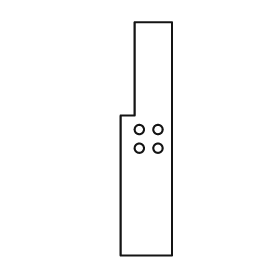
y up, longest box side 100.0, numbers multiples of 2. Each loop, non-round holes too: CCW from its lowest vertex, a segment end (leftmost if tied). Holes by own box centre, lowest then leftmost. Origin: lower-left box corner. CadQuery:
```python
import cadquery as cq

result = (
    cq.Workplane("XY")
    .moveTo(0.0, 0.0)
    .lineTo(22.0, 0.0)
    .lineTo(22.0, 100.0)
    .lineTo(6.0, 100.0)
    .lineTo(6.0, 60.0)
    .lineTo(0.0, 60.0)
    .close()
    .moveTo(8.0, 46.0)
    .circle(2.0)
    .moveTo(16.0, 46.0)
    .circle(2.0)
    .moveTo(8.0, 54.0)
    .circle(2.0)
    .moveTo(16.0, 54.0)
    .circle(2.0)
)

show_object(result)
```